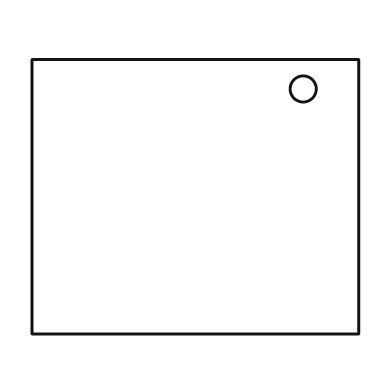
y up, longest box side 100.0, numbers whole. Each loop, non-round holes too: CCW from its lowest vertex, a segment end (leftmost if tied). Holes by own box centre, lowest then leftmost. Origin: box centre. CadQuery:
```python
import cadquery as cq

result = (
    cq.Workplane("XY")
    .moveTo(-50.0, -42.0)
    .lineTo(50.0, -42.0)
    .lineTo(50.0, 42.0)
    .lineTo(-50.0, 42.0)
    .close()
    .moveTo(33.0, 33.0)
    .circle(4.0)
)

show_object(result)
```